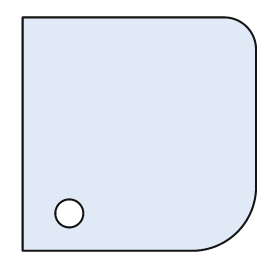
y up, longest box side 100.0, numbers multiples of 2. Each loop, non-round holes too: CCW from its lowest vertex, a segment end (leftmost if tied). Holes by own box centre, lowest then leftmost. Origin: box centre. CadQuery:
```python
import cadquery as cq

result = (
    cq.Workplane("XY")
    .moveTo(-50.0, -50.0)
    .lineTo(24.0, -50.0)
    .threePointArc((42.0, -42.0), (50.0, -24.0))
    .lineTo(50.0, 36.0)
    .threePointArc((46.0, 46.0), (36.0, 50.0))
    .lineTo(-50.0, 50.0)
    .close()
    .moveTo(-30.0, -34.0)
    .circle(6.0)
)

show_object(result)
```